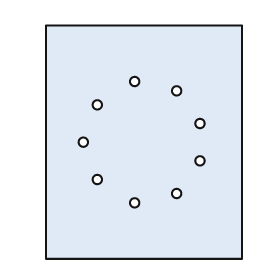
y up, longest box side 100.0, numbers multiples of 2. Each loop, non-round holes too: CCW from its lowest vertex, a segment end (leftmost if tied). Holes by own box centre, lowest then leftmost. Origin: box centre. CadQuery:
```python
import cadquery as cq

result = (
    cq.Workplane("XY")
    .moveTo(-42.0, -50.0)
    .lineTo(42.0, -50.0)
    .lineTo(42.0, 50.0)
    .lineTo(-42.0, 50.0)
    .close()
    .moveTo(-4.0, -26.0)
    .circle(2.0)
    .moveTo(14.0, -22.0)
    .circle(2.0)
    .moveTo(-20.0, -16.0)
    .circle(2.0)
    .moveTo(24.0, -8.0)
    .circle(2.0)
    .moveTo(-26.0, 0.0)
    .circle(2.0)
    .moveTo(24.0, 8.0)
    .circle(2.0)
    .moveTo(-20.0, 16.0)
    .circle(2.0)
    .moveTo(14.0, 22.0)
    .circle(2.0)
    .moveTo(-4.0, 26.0)
    .circle(2.0)
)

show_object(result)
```